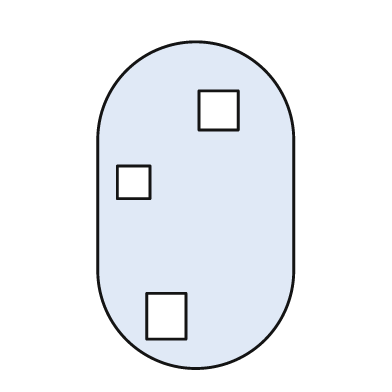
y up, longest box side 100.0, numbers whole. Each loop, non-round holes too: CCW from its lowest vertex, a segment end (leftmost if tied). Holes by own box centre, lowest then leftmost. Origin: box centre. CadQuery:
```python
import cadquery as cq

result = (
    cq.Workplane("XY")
    .moveTo(-30.0, -20.0)
    .threePointArc((0.0, -50.0), (30.0, -20.0))
    .lineTo(30.0, 20.0)
    .threePointArc((0.0, 50.0), (-30.0, 20.0))
    .close()
    .moveTo(-15.0, -41.0)
    .lineTo(-3.0, -41.0)
    .lineTo(-3.0, -27.0)
    .lineTo(-15.0, -27.0)
    .close()
    .moveTo(-24.0, 2.0)
    .lineTo(-14.0, 2.0)
    .lineTo(-14.0, 12.0)
    .lineTo(-24.0, 12.0)
    .close()
    .moveTo(1.0, 23.0)
    .lineTo(13.0, 23.0)
    .lineTo(13.0, 35.0)
    .lineTo(1.0, 35.0)
    .close()
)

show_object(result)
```